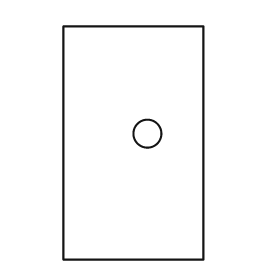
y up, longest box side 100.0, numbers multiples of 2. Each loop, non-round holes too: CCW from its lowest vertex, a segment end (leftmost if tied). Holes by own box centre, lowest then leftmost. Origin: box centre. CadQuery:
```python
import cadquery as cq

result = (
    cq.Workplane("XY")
    .moveTo(-30.0, -50.0)
    .lineTo(30.0, -50.0)
    .lineTo(30.0, 50.0)
    .lineTo(-30.0, 50.0)
    .close()
    .moveTo(6.0, 4.0)
    .circle(6.0)
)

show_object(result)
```